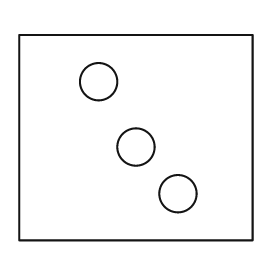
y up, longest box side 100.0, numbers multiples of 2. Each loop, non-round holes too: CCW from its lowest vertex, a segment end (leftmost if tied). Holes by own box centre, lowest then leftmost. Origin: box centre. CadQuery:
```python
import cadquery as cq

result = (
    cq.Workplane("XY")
    .moveTo(-50.0, -44.0)
    .lineTo(50.0, -44.0)
    .lineTo(50.0, 44.0)
    .lineTo(-50.0, 44.0)
    .close()
    .moveTo(18.0, -24.0)
    .circle(8.0)
    .moveTo(0.0, -4.0)
    .circle(8.0)
    .moveTo(-16.0, 24.0)
    .circle(8.0)
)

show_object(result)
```